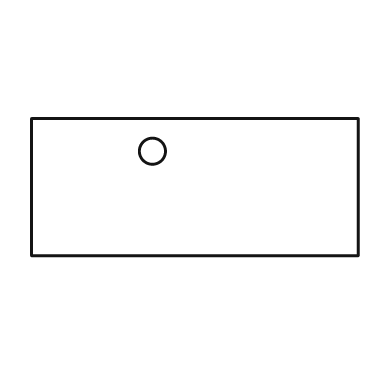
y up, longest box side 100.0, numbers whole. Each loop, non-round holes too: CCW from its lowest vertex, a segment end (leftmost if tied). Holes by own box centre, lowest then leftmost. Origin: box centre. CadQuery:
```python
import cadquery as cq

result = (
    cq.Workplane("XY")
    .moveTo(-50.0, -21.0)
    .lineTo(50.0, -21.0)
    .lineTo(50.0, 21.0)
    .lineTo(-50.0, 21.0)
    .close()
    .moveTo(-13.0, 11.0)
    .circle(4.0)
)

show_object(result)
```